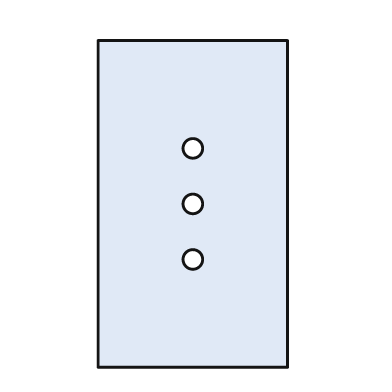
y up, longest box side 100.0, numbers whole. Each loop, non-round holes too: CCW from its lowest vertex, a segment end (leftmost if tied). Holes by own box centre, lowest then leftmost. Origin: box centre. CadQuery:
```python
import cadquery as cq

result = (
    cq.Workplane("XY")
    .moveTo(-29.0, -50.0)
    .lineTo(29.0, -50.0)
    .lineTo(29.0, 50.0)
    .lineTo(-29.0, 50.0)
    .close()
    .moveTo(0.0, -17.0)
    .circle(3.0)
    .moveTo(0.0, 0.0)
    .circle(3.0)
    .moveTo(0.0, 17.0)
    .circle(3.0)
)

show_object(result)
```